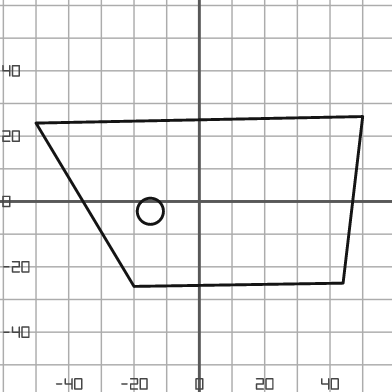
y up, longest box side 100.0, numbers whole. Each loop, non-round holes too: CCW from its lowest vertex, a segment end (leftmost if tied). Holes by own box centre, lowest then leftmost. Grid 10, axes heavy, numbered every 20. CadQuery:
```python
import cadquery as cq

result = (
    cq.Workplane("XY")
    .moveTo(-20.0, -26.0)
    .lineTo(44.0, -25.0)
    .lineTo(50.0, 26.0)
    .lineTo(-50.0, 24.0)
    .close()
    .moveTo(-15.0, -3.0)
    .circle(4.0)
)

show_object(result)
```